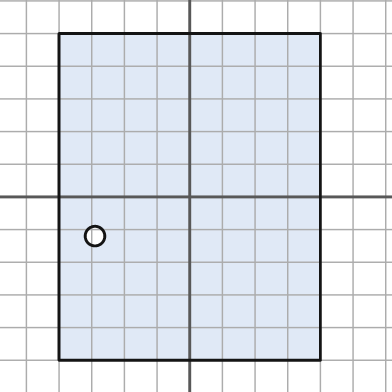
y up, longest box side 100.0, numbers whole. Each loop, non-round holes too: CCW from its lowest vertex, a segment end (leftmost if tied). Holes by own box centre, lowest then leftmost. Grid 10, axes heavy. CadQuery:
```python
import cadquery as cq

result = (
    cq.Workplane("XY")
    .moveTo(-40.0, -50.0)
    .lineTo(40.0, -50.0)
    .lineTo(40.0, 50.0)
    .lineTo(-40.0, 50.0)
    .close()
    .moveTo(-29.0, -12.0)
    .circle(3.0)
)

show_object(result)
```